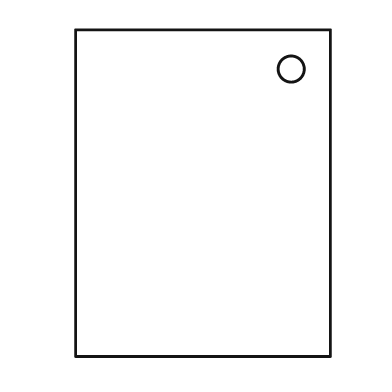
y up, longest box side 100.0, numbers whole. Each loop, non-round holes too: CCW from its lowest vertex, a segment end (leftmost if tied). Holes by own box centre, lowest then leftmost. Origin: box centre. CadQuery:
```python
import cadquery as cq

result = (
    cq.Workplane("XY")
    .moveTo(-39.0, -50.0)
    .lineTo(39.0, -50.0)
    .lineTo(39.0, 50.0)
    .lineTo(-39.0, 50.0)
    .close()
    .moveTo(27.0, 38.0)
    .circle(4.0)
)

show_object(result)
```